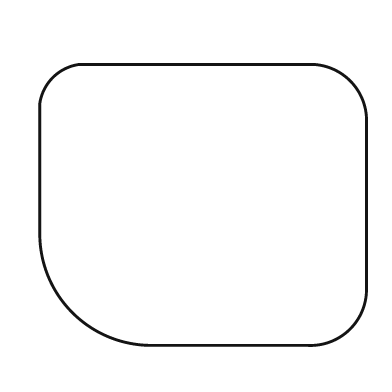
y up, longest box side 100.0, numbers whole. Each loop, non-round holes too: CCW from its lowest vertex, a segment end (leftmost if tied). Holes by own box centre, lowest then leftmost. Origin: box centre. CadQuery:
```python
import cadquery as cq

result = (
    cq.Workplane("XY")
    .moveTo(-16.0, -43.0)
    .lineTo(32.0, -43.0)
    .threePointArc((45.0, -38.0), (50.0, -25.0))
    .lineTo(50.0, 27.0)
    .threePointArc((45.0, 38.0), (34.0, 43.0))
    .lineTo(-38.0, 43.0)
    .threePointArc((-46.0, 39.0), (-50.0, 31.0))
    .lineTo(-50.0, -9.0)
    .threePointArc((-40.0, -33.0), (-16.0, -43.0))
    .close()
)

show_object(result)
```